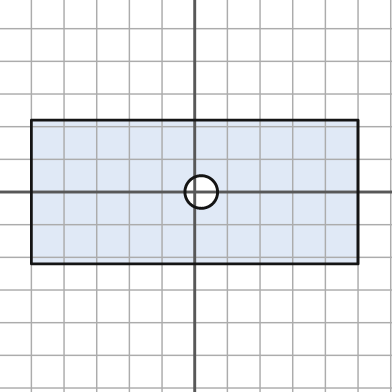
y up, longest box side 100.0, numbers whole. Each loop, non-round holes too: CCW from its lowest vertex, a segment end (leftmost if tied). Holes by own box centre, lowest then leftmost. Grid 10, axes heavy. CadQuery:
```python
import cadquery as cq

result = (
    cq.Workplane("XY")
    .moveTo(-50.0, -22.0)
    .lineTo(50.0, -22.0)
    .lineTo(50.0, 22.0)
    .lineTo(-50.0, 22.0)
    .close()
    .moveTo(2.0, 0.0)
    .circle(5.0)
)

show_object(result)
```